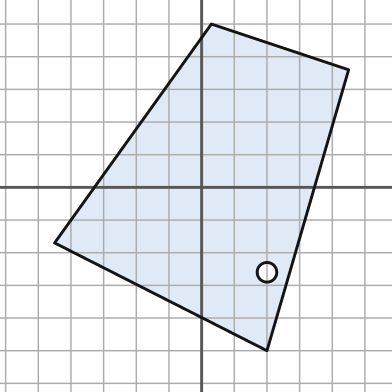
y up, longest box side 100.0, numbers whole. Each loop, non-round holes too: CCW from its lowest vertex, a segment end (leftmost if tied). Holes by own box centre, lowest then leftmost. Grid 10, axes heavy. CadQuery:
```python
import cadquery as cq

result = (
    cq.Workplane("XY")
    .moveTo(20.0, -50.0)
    .lineTo(45.0, 36.0)
    .lineTo(3.0, 50.0)
    .lineTo(-45.0, -17.0)
    .close()
    .moveTo(20.0, -26.0)
    .circle(3.0)
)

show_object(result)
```